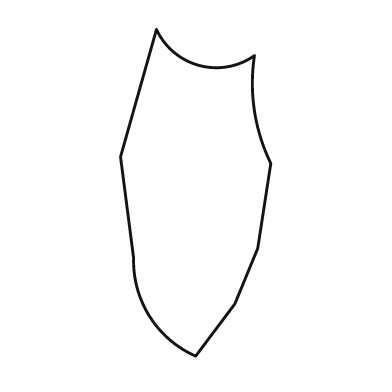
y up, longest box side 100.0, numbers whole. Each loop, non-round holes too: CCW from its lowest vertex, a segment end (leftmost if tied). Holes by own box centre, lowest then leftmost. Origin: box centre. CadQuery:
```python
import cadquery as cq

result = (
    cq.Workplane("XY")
    .moveTo(0.0, -50.0)
    .lineTo(12.0, -34.0)
    .lineTo(19.0, -17.0)
    .lineTo(23.0, 9.0)
    .threePointArc((18.0, 25.0), (18.0, 42.0))
    .threePointArc((1.0, 39.0), (-12.0, 50.0))
    .lineTo(-23.0, 11.0)
    .lineTo(-19.0, -20.0)
    .threePointArc((-14.0, -38.0), (0.0, -50.0))
    .close()
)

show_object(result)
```